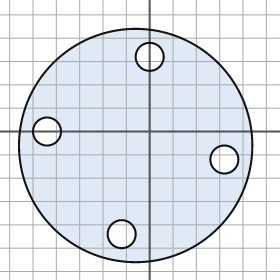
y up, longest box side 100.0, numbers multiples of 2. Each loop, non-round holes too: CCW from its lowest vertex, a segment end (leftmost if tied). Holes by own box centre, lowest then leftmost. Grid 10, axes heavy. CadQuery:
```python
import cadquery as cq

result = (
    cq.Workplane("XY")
    .moveTo(-6.0, -6.0)
    .circle(50.0)
    .moveTo(-12.0, -44.0)
    .circle(6.0)
    .moveTo(32.0, -12.0)
    .circle(6.0)
    .moveTo(-44.0, 0.0)
    .circle(6.0)
    .moveTo(0.0, 32.0)
    .circle(6.0)
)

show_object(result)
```